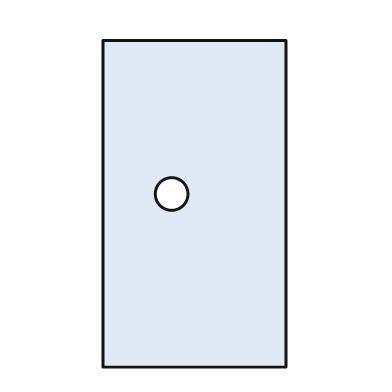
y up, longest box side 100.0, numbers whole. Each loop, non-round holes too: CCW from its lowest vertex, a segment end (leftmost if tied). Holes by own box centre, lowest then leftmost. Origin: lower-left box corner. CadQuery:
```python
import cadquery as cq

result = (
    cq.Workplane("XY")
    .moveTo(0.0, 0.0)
    .lineTo(56.0, 0.0)
    .lineTo(56.0, 100.0)
    .lineTo(0.0, 100.0)
    .close()
    .moveTo(21.0, 53.0)
    .circle(5.0)
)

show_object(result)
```